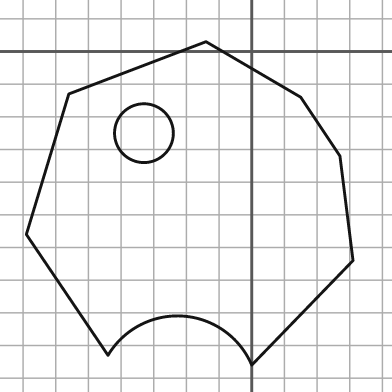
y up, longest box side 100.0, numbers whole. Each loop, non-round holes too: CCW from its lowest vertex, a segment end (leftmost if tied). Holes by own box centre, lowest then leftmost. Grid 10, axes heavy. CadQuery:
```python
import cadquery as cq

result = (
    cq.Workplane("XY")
    .moveTo(0.0, -96.0)
    .lineTo(31.0, -64.0)
    .lineTo(27.0, -32.0)
    .lineTo(15.0, -14.0)
    .lineTo(-14.0, 3.0)
    .lineTo(-56.0, -13.0)
    .lineTo(-69.0, -56.0)
    .lineTo(-44.0, -93.0)
    .threePointArc((-21.0, -81.0), (0.0, -96.0))
    .close()
    .moveTo(-33.0, -25.0)
    .circle(9.0)
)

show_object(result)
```